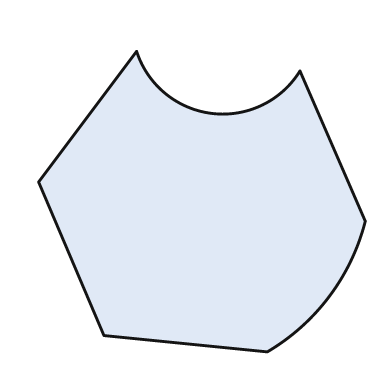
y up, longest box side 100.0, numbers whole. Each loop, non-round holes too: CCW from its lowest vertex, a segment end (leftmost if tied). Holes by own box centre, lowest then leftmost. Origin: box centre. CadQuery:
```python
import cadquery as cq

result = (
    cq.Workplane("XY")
    .moveTo(20.0, -46.0)
    .threePointArc((39.0, -29.0), (50.0, -6.0))
    .lineTo(30.0, 40.0)
    .threePointArc((3.0, 27.0), (-20.0, 46.0))
    .lineTo(-50.0, 6.0)
    .lineTo(-30.0, -41.0)
    .close()
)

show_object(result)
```